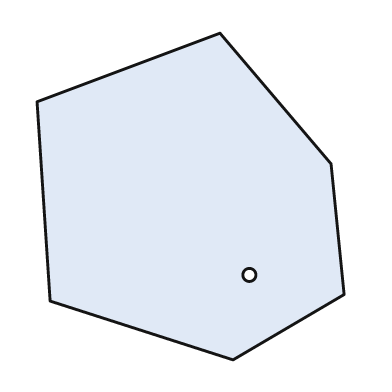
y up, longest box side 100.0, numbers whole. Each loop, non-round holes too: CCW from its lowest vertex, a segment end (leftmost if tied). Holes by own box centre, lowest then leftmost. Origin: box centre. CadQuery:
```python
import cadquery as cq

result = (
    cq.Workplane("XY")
    .moveTo(13.0, -50.0)
    .lineTo(47.0, -30.0)
    .lineTo(43.0, 10.0)
    .lineTo(9.0, 50.0)
    .lineTo(-47.0, 29.0)
    .lineTo(-43.0, -32.0)
    .close()
    .moveTo(18.0, -24.0)
    .circle(2.0)
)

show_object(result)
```